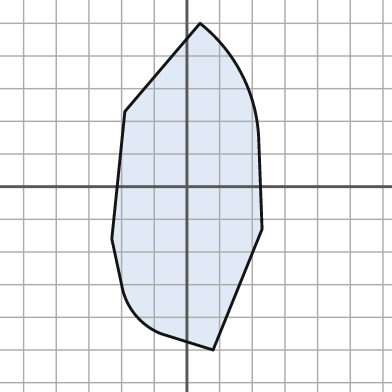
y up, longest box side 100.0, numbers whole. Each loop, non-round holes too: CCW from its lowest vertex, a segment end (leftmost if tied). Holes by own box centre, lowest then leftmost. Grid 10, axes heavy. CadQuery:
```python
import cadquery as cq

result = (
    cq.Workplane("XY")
    .moveTo(8.0, -50.0)
    .lineTo(23.0, -13.0)
    .lineTo(22.0, 14.0)
    .threePointArc((17.0, 34.0), (4.0, 50.0))
    .lineTo(-19.0, 23.0)
    .lineTo(-23.0, -16.0)
    .lineTo(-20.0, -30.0)
    .threePointArc((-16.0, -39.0), (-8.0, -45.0))
    .close()
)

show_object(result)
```